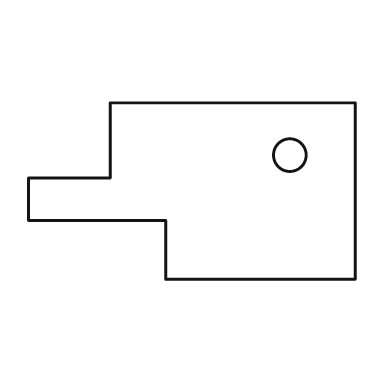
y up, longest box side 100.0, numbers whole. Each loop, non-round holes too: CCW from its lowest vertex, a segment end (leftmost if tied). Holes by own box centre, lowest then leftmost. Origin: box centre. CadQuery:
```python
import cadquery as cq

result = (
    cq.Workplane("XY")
    .moveTo(-8.0, -27.0)
    .lineTo(50.0, -27.0)
    .lineTo(50.0, 27.0)
    .lineTo(-25.0, 27.0)
    .lineTo(-25.0, 4.0)
    .lineTo(-50.0, 4.0)
    .lineTo(-50.0, -9.0)
    .lineTo(-8.0, -9.0)
    .close()
    .moveTo(30.0, 11.0)
    .circle(5.0)
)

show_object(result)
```